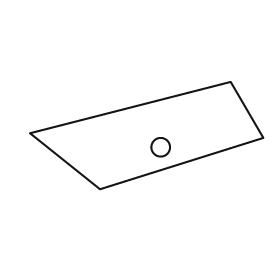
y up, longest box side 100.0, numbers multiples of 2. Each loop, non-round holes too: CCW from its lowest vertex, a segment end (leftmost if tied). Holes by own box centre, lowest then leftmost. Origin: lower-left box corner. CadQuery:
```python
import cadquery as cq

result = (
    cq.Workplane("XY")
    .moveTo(30.0, 0.0)
    .lineTo(100.0, 22.0)
    .lineTo(86.0, 46.0)
    .lineTo(0.0, 24.0)
    .close()
    .moveTo(56.0, 18.0)
    .circle(4.0)
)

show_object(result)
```